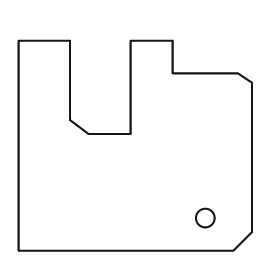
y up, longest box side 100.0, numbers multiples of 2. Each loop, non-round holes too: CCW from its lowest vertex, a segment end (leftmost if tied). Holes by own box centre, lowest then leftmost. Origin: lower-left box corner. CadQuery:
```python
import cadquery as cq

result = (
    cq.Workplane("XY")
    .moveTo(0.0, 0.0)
    .lineTo(92.0, 0.0)
    .lineTo(100.0, 8.0)
    .lineTo(100.0, 72.0)
    .lineTo(94.0, 76.0)
    .lineTo(66.0, 76.0)
    .lineTo(66.0, 90.0)
    .lineTo(48.0, 90.0)
    .lineTo(48.0, 50.0)
    .lineTo(30.0, 50.0)
    .lineTo(22.0, 56.0)
    .lineTo(22.0, 90.0)
    .lineTo(0.0, 90.0)
    .close()
    .moveTo(80.0, 14.0)
    .circle(4.0)
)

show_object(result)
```